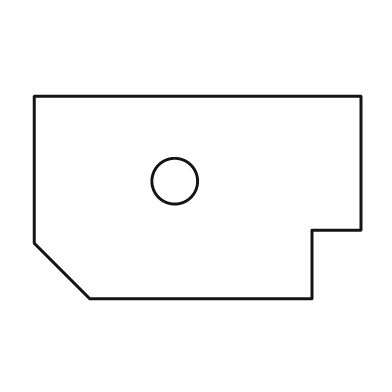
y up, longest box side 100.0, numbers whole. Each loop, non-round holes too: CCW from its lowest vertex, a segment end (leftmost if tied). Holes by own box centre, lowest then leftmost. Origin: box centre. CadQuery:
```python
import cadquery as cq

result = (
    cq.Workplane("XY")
    .moveTo(-33.0, -31.0)
    .lineTo(35.0, -31.0)
    .lineTo(35.0, -10.0)
    .lineTo(50.0, -10.0)
    .lineTo(50.0, 31.0)
    .lineTo(-50.0, 31.0)
    .lineTo(-50.0, -14.0)
    .close()
    .moveTo(-7.0, 5.0)
    .circle(7.0)
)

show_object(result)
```